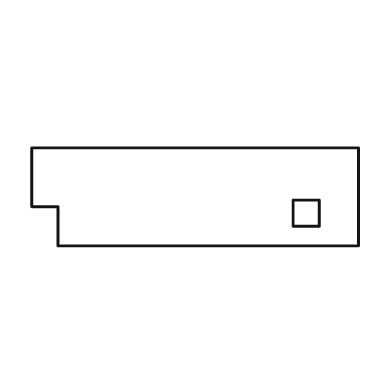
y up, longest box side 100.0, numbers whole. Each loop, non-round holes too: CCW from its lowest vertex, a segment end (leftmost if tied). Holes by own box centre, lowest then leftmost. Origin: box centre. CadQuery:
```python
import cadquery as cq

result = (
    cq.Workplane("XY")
    .moveTo(-42.0, -15.0)
    .lineTo(50.0, -15.0)
    .lineTo(50.0, 15.0)
    .lineTo(-50.0, 15.0)
    .lineTo(-50.0, -3.0)
    .lineTo(-42.0, -3.0)
    .close()
    .moveTo(30.0, -9.0)
    .lineTo(38.0, -9.0)
    .lineTo(38.0, -1.0)
    .lineTo(30.0, -1.0)
    .close()
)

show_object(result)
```